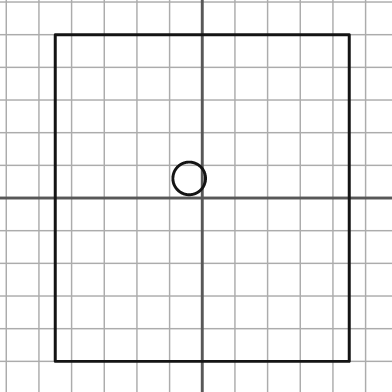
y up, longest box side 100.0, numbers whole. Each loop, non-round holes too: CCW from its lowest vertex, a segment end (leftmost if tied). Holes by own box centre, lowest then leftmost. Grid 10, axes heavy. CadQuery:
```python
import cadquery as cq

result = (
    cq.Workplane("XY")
    .moveTo(-45.0, -50.0)
    .lineTo(45.0, -50.0)
    .lineTo(45.0, 50.0)
    .lineTo(-45.0, 50.0)
    .close()
    .moveTo(-4.0, 6.0)
    .circle(5.0)
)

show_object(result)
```